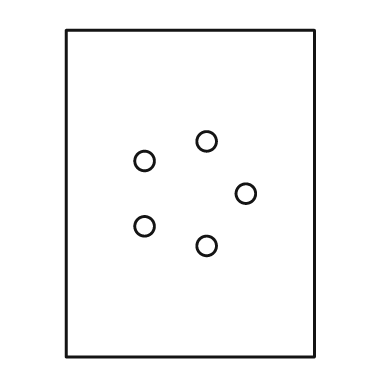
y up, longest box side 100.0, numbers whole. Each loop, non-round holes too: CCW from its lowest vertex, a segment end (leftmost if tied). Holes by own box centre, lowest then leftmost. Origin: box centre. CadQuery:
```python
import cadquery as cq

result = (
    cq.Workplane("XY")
    .moveTo(-38.0, -50.0)
    .lineTo(38.0, -50.0)
    .lineTo(38.0, 50.0)
    .lineTo(-38.0, 50.0)
    .close()
    .moveTo(5.0, -16.0)
    .circle(3.0)
    .moveTo(-14.0, -10.0)
    .circle(3.0)
    .moveTo(17.0, 0.0)
    .circle(3.0)
    .moveTo(-14.0, 10.0)
    .circle(3.0)
    .moveTo(5.0, 16.0)
    .circle(3.0)
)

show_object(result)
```